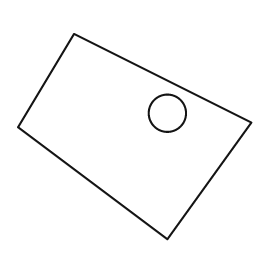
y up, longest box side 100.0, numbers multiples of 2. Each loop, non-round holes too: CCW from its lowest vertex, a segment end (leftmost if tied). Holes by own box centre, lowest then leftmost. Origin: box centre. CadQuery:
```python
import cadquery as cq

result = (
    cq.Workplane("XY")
    .moveTo(14.0, -44.0)
    .lineTo(50.0, 6.0)
    .lineTo(-26.0, 44.0)
    .lineTo(-50.0, 4.0)
    .close()
    .moveTo(14.0, 10.0)
    .circle(8.0)
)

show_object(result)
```